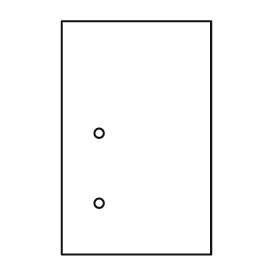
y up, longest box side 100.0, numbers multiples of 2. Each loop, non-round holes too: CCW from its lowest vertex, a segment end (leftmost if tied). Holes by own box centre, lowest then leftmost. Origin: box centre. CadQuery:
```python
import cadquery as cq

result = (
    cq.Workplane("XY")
    .moveTo(-32.0, -50.0)
    .lineTo(32.0, -50.0)
    .lineTo(32.0, 50.0)
    .lineTo(-32.0, 50.0)
    .close()
    .moveTo(-16.0, -28.0)
    .circle(2.0)
    .moveTo(-16.0, 2.0)
    .circle(2.0)
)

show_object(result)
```